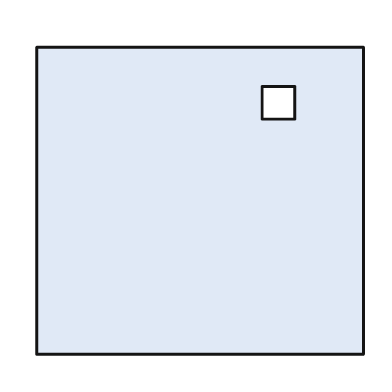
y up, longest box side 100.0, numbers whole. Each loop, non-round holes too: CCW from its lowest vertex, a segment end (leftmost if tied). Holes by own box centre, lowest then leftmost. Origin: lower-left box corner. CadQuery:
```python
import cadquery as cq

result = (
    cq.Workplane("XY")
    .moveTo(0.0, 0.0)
    .lineTo(100.0, 0.0)
    .lineTo(100.0, 94.0)
    .lineTo(0.0, 94.0)
    .close()
    .moveTo(69.0, 72.0)
    .lineTo(79.0, 72.0)
    .lineTo(79.0, 82.0)
    .lineTo(69.0, 82.0)
    .close()
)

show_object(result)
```